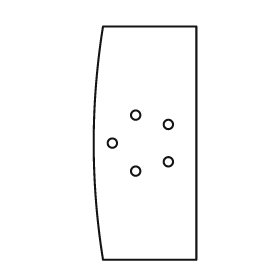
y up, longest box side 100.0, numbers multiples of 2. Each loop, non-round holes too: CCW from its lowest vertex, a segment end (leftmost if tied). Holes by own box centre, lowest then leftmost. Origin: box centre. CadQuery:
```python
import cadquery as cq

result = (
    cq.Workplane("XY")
    .moveTo(-18.0, -50.0)
    .lineTo(22.0, -50.0)
    .lineTo(22.0, 50.0)
    .lineTo(-18.0, 50.0)
    .threePointArc((-22.0, 0.0), (-18.0, -50.0))
    .close()
    .moveTo(-4.0, -12.0)
    .circle(2.0)
    .moveTo(10.0, -8.0)
    .circle(2.0)
    .moveTo(-14.0, 0.0)
    .circle(2.0)
    .moveTo(10.0, 8.0)
    .circle(2.0)
    .moveTo(-4.0, 12.0)
    .circle(2.0)
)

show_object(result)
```